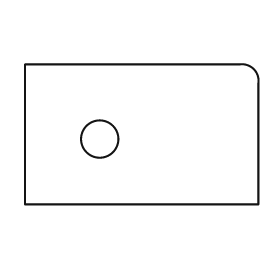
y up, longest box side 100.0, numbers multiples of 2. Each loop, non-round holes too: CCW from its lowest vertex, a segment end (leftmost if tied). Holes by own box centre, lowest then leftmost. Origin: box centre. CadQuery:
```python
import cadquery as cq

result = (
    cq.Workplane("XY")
    .moveTo(-50.0, -30.0)
    .lineTo(50.0, -30.0)
    .lineTo(50.0, 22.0)
    .threePointArc((48.0, 28.0), (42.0, 30.0))
    .lineTo(-50.0, 30.0)
    .close()
    .moveTo(-18.0, -2.0)
    .circle(8.0)
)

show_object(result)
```